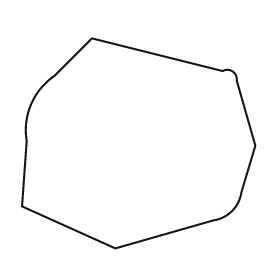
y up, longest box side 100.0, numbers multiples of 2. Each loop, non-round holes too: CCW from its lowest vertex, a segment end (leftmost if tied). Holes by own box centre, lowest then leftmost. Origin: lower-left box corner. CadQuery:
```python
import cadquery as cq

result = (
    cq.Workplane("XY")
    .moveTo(40.0, 0.0)
    .lineTo(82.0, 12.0)
    .threePointArc((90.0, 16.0), (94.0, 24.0))
    .lineTo(100.0, 44.0)
    .lineTo(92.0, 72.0)
    .threePointArc((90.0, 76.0), (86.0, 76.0))
    .lineTo(30.0, 90.0)
    .lineTo(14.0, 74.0)
    .threePointArc((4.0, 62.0), (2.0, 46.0))
    .lineTo(0.0, 18.0)
    .close()
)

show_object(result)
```